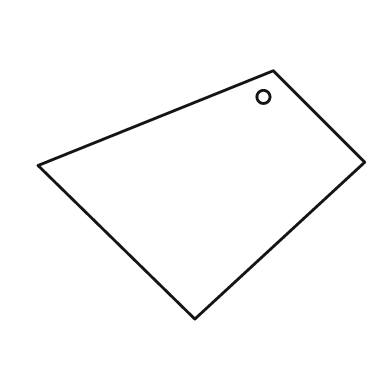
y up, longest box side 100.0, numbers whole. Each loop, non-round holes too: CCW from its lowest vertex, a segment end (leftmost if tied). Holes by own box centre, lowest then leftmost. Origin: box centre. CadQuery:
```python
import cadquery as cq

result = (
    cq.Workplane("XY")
    .moveTo(-2.0, -38.0)
    .lineTo(50.0, 10.0)
    .lineTo(22.0, 38.0)
    .lineTo(-50.0, 9.0)
    .close()
    .moveTo(19.0, 30.0)
    .circle(2.0)
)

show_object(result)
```